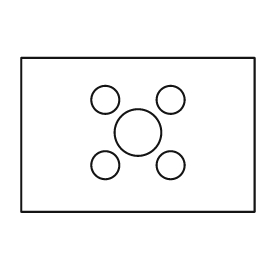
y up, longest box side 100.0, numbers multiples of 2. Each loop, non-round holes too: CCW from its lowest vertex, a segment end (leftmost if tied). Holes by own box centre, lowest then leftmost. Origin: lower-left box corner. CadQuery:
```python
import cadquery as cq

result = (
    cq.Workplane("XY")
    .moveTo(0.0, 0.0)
    .lineTo(100.0, 0.0)
    .lineTo(100.0, 66.0)
    .lineTo(0.0, 66.0)
    .close()
    .moveTo(36.0, 20.0)
    .circle(6.0)
    .moveTo(64.0, 20.0)
    .circle(6.0)
    .moveTo(50.0, 34.0)
    .circle(10.0)
    .moveTo(36.0, 48.0)
    .circle(6.0)
    .moveTo(64.0, 48.0)
    .circle(6.0)
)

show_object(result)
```